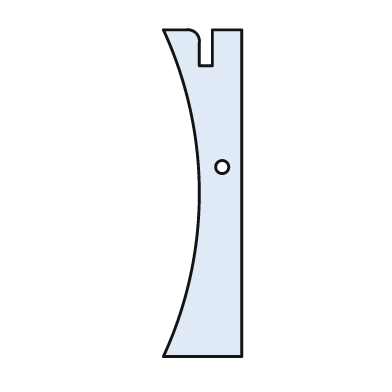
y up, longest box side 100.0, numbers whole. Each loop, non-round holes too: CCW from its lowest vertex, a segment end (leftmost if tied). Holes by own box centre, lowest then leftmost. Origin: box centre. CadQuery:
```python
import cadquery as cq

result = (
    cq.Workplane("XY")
    .moveTo(-12.0, -50.0)
    .lineTo(12.0, -50.0)
    .lineTo(12.0, 50.0)
    .lineTo(3.0, 50.0)
    .lineTo(3.0, 39.0)
    .lineTo(-1.0, 39.0)
    .lineTo(-1.0, 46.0)
    .threePointArc((-2.0, 49.0), (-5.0, 50.0))
    .lineTo(-12.0, 50.0)
    .threePointArc((-1.0, 0.0), (-12.0, -50.0))
    .close()
    .moveTo(6.0, 8.0)
    .circle(2.0)
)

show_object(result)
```